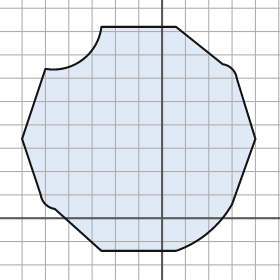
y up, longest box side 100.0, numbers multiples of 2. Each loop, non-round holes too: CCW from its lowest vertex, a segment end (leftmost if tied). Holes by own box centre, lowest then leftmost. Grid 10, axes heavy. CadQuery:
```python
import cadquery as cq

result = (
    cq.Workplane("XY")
    .moveTo(-26.0, -14.0)
    .lineTo(6.0, -14.0)
    .threePointArc((20.0, -6.0), (30.0, 6.0))
    .lineTo(40.0, 34.0)
    .lineTo(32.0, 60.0)
    .threePointArc((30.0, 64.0), (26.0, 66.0))
    .lineTo(6.0, 82.0)
    .lineTo(-26.0, 82.0)
    .threePointArc((-34.0, 68.0), (-50.0, 64.0))
    .lineTo(-60.0, 34.0)
    .lineTo(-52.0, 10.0)
    .threePointArc((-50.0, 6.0), (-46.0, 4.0))
    .close()
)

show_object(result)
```